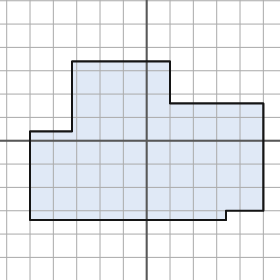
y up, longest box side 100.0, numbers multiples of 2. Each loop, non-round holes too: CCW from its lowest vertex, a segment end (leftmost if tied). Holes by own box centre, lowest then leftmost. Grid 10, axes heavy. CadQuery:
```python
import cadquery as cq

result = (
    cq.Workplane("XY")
    .moveTo(-50.0, -34.0)
    .lineTo(34.0, -34.0)
    .lineTo(34.0, -30.0)
    .lineTo(50.0, -30.0)
    .lineTo(50.0, 16.0)
    .lineTo(10.0, 16.0)
    .lineTo(10.0, 34.0)
    .lineTo(-32.0, 34.0)
    .lineTo(-32.0, 4.0)
    .lineTo(-50.0, 4.0)
    .close()
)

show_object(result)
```